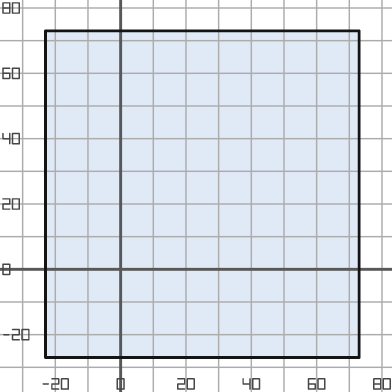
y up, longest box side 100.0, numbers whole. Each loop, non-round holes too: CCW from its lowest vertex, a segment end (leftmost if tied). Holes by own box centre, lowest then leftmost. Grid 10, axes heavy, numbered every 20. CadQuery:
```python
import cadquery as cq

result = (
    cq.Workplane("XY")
    .moveTo(-23.0, -27.0)
    .lineTo(73.0, -27.0)
    .lineTo(73.0, 73.0)
    .lineTo(-23.0, 73.0)
    .close()
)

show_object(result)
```